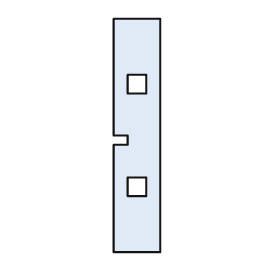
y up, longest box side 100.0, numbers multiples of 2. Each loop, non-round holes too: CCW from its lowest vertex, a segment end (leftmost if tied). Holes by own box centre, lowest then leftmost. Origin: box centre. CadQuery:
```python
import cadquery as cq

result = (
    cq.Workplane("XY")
    .moveTo(-10.0, -50.0)
    .lineTo(10.0, -50.0)
    .lineTo(10.0, 50.0)
    .lineTo(-10.0, 50.0)
    .lineTo(-10.0, 0.0)
    .lineTo(-4.0, 0.0)
    .lineTo(-4.0, -4.0)
    .lineTo(-10.0, -4.0)
    .close()
    .moveTo(-4.0, -26.0)
    .lineTo(4.0, -26.0)
    .lineTo(4.0, -18.0)
    .lineTo(-4.0, -18.0)
    .close()
    .moveTo(-4.0, 18.0)
    .lineTo(4.0, 18.0)
    .lineTo(4.0, 26.0)
    .lineTo(-4.0, 26.0)
    .close()
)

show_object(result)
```